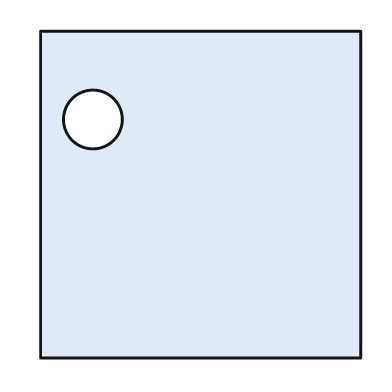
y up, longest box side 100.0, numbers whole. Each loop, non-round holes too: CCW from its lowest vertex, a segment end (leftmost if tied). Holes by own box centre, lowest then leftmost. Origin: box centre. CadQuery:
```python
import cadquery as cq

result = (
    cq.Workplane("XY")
    .moveTo(-49.0, -50.0)
    .lineTo(49.0, -50.0)
    .lineTo(49.0, 50.0)
    .lineTo(-49.0, 50.0)
    .close()
    .moveTo(-33.0, 23.0)
    .circle(9.0)
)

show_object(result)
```